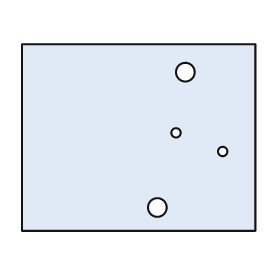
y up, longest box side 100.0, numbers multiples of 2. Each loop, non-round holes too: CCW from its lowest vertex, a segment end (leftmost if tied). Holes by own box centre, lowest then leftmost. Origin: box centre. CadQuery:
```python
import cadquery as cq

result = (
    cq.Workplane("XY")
    .moveTo(-50.0, -40.0)
    .lineTo(50.0, -40.0)
    .lineTo(50.0, 40.0)
    .lineTo(-50.0, 40.0)
    .close()
    .moveTo(8.0, -30.0)
    .circle(4.0)
    .moveTo(36.0, -6.0)
    .circle(2.0)
    .moveTo(16.0, 2.0)
    .circle(2.0)
    .moveTo(20.0, 28.0)
    .circle(4.0)
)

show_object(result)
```